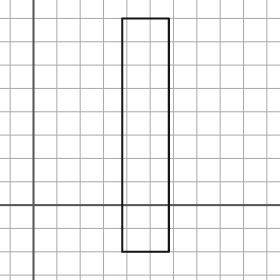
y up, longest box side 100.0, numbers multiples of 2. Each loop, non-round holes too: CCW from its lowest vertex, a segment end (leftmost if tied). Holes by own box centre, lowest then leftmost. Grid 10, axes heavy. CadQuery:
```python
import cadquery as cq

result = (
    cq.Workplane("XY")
    .moveTo(38.0, -20.0)
    .lineTo(58.0, -20.0)
    .lineTo(58.0, 80.0)
    .lineTo(38.0, 80.0)
    .close()
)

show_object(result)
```